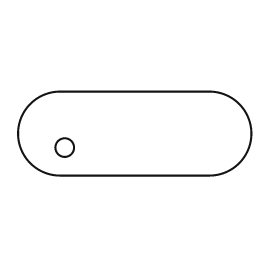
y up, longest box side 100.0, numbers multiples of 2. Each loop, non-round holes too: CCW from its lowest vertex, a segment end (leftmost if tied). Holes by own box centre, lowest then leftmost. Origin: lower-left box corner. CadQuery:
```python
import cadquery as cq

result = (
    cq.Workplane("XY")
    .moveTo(18.0, 0.0)
    .lineTo(82.0, 0.0)
    .threePointArc((100.0, 18.0), (82.0, 36.0))
    .lineTo(18.0, 36.0)
    .threePointArc((0.0, 18.0), (18.0, 0.0))
    .close()
    .moveTo(20.0, 12.0)
    .circle(4.0)
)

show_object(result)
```